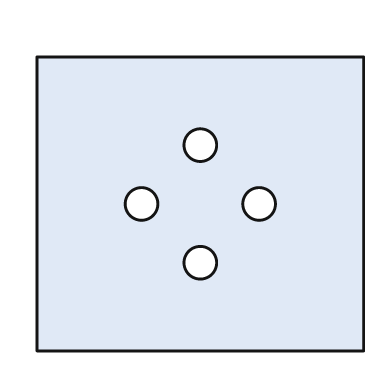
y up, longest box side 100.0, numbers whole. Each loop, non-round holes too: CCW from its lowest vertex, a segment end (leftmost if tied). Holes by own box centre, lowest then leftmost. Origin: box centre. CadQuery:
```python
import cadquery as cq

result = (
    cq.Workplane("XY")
    .moveTo(-50.0, -45.0)
    .lineTo(50.0, -45.0)
    .lineTo(50.0, 45.0)
    .lineTo(-50.0, 45.0)
    .close()
    .moveTo(0.0, -18.0)
    .circle(5.0)
    .moveTo(-18.0, 0.0)
    .circle(5.0)
    .moveTo(18.0, 0.0)
    .circle(5.0)
    .moveTo(0.0, 18.0)
    .circle(5.0)
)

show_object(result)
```